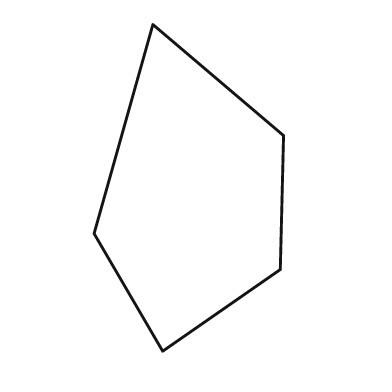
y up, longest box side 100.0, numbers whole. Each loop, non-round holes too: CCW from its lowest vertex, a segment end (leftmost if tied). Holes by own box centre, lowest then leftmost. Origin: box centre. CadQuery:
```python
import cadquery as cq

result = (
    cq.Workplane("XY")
    .moveTo(-8.0, -50.0)
    .lineTo(28.0, -25.0)
    .lineTo(29.0, 16.0)
    .lineTo(-11.0, 50.0)
    .lineTo(-29.0, -14.0)
    .close()
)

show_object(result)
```